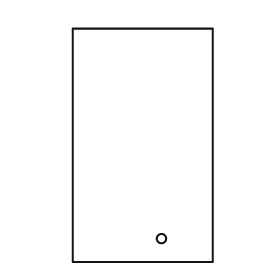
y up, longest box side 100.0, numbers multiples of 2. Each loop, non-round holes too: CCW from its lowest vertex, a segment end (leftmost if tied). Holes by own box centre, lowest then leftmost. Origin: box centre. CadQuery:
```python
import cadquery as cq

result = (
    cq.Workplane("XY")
    .moveTo(-30.0, -50.0)
    .lineTo(30.0, -50.0)
    .lineTo(30.0, 50.0)
    .lineTo(-30.0, 50.0)
    .close()
    .moveTo(8.0, -40.0)
    .circle(2.0)
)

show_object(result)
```